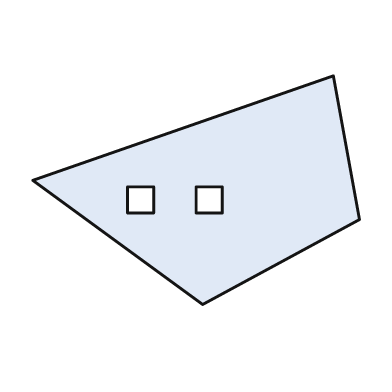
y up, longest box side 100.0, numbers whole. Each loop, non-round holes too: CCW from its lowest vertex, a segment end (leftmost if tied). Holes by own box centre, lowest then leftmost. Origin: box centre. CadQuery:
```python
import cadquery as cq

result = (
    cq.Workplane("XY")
    .moveTo(2.0, -35.0)
    .lineTo(50.0, -9.0)
    .lineTo(42.0, 35.0)
    .lineTo(-50.0, 3.0)
    .close()
    .moveTo(-21.0, -7.0)
    .lineTo(-13.0, -7.0)
    .lineTo(-13.0, 1.0)
    .lineTo(-21.0, 1.0)
    .close()
    .moveTo(0.0, -7.0)
    .lineTo(8.0, -7.0)
    .lineTo(8.0, 1.0)
    .lineTo(0.0, 1.0)
    .close()
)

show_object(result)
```